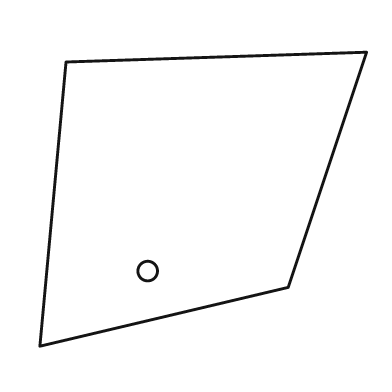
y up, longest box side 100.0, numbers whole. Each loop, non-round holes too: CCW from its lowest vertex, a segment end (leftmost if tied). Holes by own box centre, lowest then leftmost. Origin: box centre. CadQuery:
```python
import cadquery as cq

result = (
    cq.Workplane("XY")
    .moveTo(-50.0, -45.0)
    .lineTo(26.0, -27.0)
    .lineTo(50.0, 45.0)
    .lineTo(-42.0, 42.0)
    .close()
    .moveTo(-17.0, -22.0)
    .circle(3.0)
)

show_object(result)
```